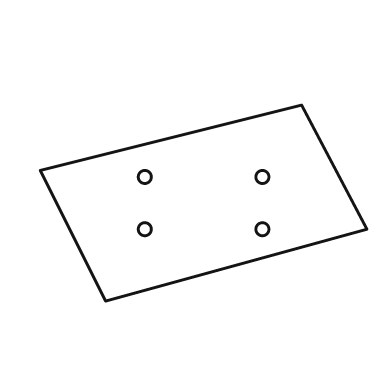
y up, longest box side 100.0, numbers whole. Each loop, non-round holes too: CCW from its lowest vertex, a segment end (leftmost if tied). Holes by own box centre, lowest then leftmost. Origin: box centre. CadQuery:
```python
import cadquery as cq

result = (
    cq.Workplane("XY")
    .moveTo(-30.0, -30.0)
    .lineTo(50.0, -8.0)
    .lineTo(30.0, 30.0)
    .lineTo(-50.0, 10.0)
    .close()
    .moveTo(-18.0, -8.0)
    .circle(2.0)
    .moveTo(18.0, -8.0)
    .circle(2.0)
    .moveTo(-18.0, 8.0)
    .circle(2.0)
    .moveTo(18.0, 8.0)
    .circle(2.0)
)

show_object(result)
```